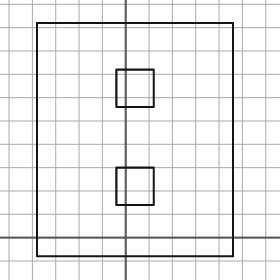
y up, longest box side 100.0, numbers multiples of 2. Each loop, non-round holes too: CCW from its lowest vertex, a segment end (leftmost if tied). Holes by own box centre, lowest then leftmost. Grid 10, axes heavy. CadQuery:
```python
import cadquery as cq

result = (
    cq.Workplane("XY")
    .moveTo(-38.0, -8.0)
    .lineTo(46.0, -8.0)
    .lineTo(46.0, 92.0)
    .lineTo(-38.0, 92.0)
    .close()
    .moveTo(-4.0, 14.0)
    .lineTo(12.0, 14.0)
    .lineTo(12.0, 30.0)
    .lineTo(-4.0, 30.0)
    .close()
    .moveTo(-4.0, 56.0)
    .lineTo(12.0, 56.0)
    .lineTo(12.0, 72.0)
    .lineTo(-4.0, 72.0)
    .close()
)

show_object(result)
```